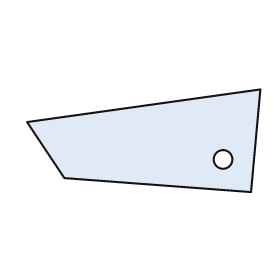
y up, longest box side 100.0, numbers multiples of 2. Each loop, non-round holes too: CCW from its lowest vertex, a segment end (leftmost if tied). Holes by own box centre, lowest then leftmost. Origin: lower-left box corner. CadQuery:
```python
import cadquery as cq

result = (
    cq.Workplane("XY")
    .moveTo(96.0, 0.0)
    .lineTo(100.0, 44.0)
    .lineTo(0.0, 30.0)
    .lineTo(16.0, 6.0)
    .close()
    .moveTo(84.0, 14.0)
    .circle(4.0)
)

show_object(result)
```